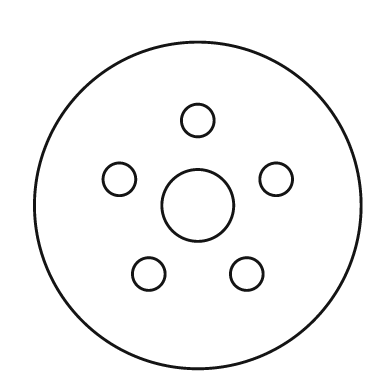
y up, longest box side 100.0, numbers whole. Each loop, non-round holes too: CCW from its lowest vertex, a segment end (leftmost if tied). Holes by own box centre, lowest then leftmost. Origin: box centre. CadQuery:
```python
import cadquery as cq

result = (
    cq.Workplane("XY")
    .moveTo(0.0, 0.0)
    .circle(50.0)
    .moveTo(-15.0, -21.0)
    .circle(5.0)
    .moveTo(15.0, -21.0)
    .circle(5.0)
    .moveTo(0.0, 0.0)
    .circle(11.0)
    .moveTo(-24.0, 8.0)
    .circle(5.0)
    .moveTo(24.0, 8.0)
    .circle(5.0)
    .moveTo(0.0, 26.0)
    .circle(5.0)
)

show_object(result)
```